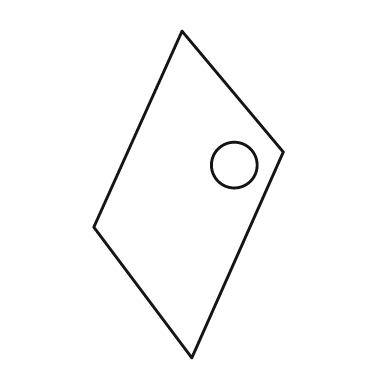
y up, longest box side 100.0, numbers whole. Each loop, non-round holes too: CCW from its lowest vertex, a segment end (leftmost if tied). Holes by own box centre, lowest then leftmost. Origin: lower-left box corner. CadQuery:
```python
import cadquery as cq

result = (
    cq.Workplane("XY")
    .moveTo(30.0, 0.0)
    .lineTo(58.0, 63.0)
    .lineTo(27.0, 100.0)
    .lineTo(0.0, 40.0)
    .close()
    .moveTo(43.0, 59.0)
    .circle(7.0)
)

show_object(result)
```